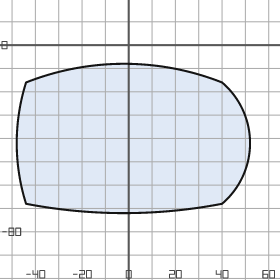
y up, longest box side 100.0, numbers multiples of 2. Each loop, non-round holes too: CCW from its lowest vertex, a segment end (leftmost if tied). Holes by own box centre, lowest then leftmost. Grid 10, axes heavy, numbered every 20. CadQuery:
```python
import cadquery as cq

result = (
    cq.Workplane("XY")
    .moveTo(-44.0, -68.0)
    .threePointArc((-2.0, -72.0), (40.0, -68.0))
    .threePointArc((52.0, -42.0), (40.0, -16.0))
    .threePointArc((-2.0, -8.0), (-44.0, -16.0))
    .threePointArc((-48.0, -42.0), (-44.0, -68.0))
    .close()
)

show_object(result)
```